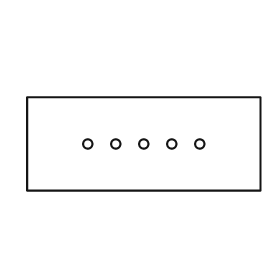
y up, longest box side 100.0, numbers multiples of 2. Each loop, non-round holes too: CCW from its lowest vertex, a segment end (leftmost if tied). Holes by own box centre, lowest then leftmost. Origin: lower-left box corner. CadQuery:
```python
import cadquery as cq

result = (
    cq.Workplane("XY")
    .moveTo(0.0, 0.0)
    .lineTo(100.0, 0.0)
    .lineTo(100.0, 40.0)
    .lineTo(0.0, 40.0)
    .close()
    .moveTo(26.0, 20.0)
    .circle(2.0)
    .moveTo(38.0, 20.0)
    .circle(2.0)
    .moveTo(50.0, 20.0)
    .circle(2.0)
    .moveTo(62.0, 20.0)
    .circle(2.0)
    .moveTo(74.0, 20.0)
    .circle(2.0)
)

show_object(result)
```